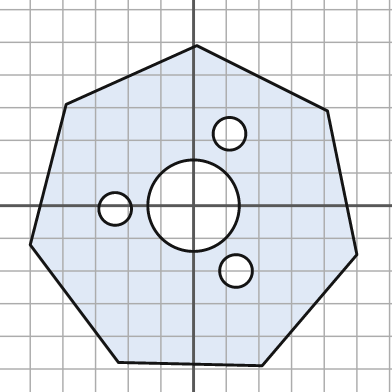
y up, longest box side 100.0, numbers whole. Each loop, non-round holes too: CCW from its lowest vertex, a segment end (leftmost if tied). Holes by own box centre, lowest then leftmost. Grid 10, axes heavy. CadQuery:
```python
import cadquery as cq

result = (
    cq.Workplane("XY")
    .moveTo(21.0, -49.0)
    .lineTo(50.0, -15.0)
    .lineTo(41.0, 29.0)
    .lineTo(1.0, 49.0)
    .lineTo(-39.0, 31.0)
    .lineTo(-50.0, -12.0)
    .lineTo(-23.0, -48.0)
    .close()
    .moveTo(13.0, -20.0)
    .circle(5.0)
    .moveTo(-24.0, -1.0)
    .circle(5.0)
    .moveTo(0.0, 0.0)
    .circle(14.0)
    .moveTo(11.0, 22.0)
    .circle(5.0)
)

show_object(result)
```